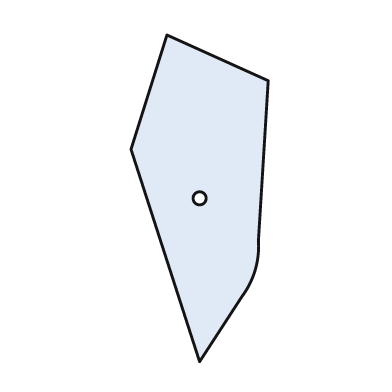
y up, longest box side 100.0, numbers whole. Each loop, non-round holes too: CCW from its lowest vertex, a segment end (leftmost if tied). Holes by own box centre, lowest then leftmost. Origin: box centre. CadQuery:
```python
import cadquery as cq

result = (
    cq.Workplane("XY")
    .moveTo(0.0, -50.0)
    .lineTo(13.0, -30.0)
    .threePointArc((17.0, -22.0), (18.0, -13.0))
    .lineTo(21.0, 36.0)
    .lineTo(-10.0, 50.0)
    .lineTo(-21.0, 15.0)
    .close()
    .moveTo(0.0, 0.0)
    .circle(2.0)
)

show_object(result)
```